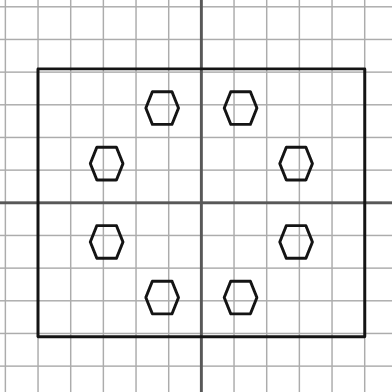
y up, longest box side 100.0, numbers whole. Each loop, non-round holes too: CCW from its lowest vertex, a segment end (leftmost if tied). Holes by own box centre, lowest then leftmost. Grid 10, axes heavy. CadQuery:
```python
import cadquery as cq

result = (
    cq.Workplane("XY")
    .moveTo(-50.0, -41.0)
    .lineTo(50.0, -41.0)
    .lineTo(50.0, 41.0)
    .lineTo(-50.0, 41.0)
    .close()
    .moveTo(-15.0, -34.0)
    .lineTo(-9.0, -34.0)
    .lineTo(-7.0, -29.0)
    .lineTo(-9.0, -24.0)
    .lineTo(-15.0, -24.0)
    .lineTo(-17.0, -29.0)
    .close()
    .moveTo(9.0, -34.0)
    .lineTo(15.0, -34.0)
    .lineTo(17.0, -29.0)
    .lineTo(15.0, -24.0)
    .lineTo(9.0, -24.0)
    .lineTo(7.0, -29.0)
    .close()
    .moveTo(-32.0, -17.0)
    .lineTo(-26.0, -17.0)
    .lineTo(-24.0, -12.0)
    .lineTo(-26.0, -7.0)
    .lineTo(-32.0, -7.0)
    .lineTo(-34.0, -12.0)
    .close()
    .moveTo(26.0, -17.0)
    .lineTo(32.0, -17.0)
    .lineTo(34.0, -12.0)
    .lineTo(32.0, -7.0)
    .lineTo(26.0, -7.0)
    .lineTo(24.0, -12.0)
    .close()
    .moveTo(-32.0, 7.0)
    .lineTo(-26.0, 7.0)
    .lineTo(-24.0, 12.0)
    .lineTo(-26.0, 17.0)
    .lineTo(-32.0, 17.0)
    .lineTo(-34.0, 12.0)
    .close()
    .moveTo(26.0, 7.0)
    .lineTo(32.0, 7.0)
    .lineTo(34.0, 12.0)
    .lineTo(32.0, 17.0)
    .lineTo(26.0, 17.0)
    .lineTo(24.0, 12.0)
    .close()
    .moveTo(-15.0, 24.0)
    .lineTo(-9.0, 24.0)
    .lineTo(-7.0, 29.0)
    .lineTo(-9.0, 34.0)
    .lineTo(-15.0, 34.0)
    .lineTo(-17.0, 29.0)
    .close()
    .moveTo(9.0, 24.0)
    .lineTo(15.0, 24.0)
    .lineTo(17.0, 29.0)
    .lineTo(15.0, 34.0)
    .lineTo(9.0, 34.0)
    .lineTo(7.0, 29.0)
    .close()
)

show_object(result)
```